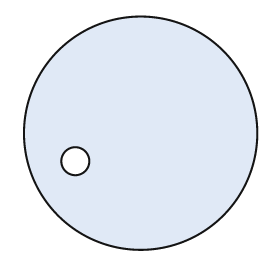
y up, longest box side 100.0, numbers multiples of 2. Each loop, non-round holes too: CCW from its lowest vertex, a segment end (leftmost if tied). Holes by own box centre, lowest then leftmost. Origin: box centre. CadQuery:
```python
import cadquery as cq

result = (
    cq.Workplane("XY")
    .moveTo(0.0, 0.0)
    .circle(50.0)
    .moveTo(-28.0, -12.0)
    .circle(6.0)
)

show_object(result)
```